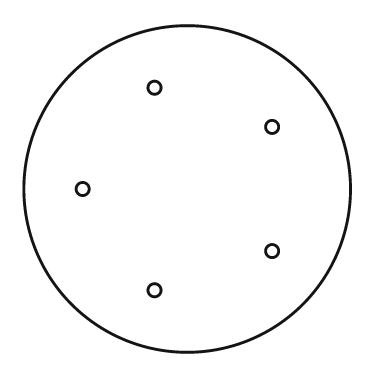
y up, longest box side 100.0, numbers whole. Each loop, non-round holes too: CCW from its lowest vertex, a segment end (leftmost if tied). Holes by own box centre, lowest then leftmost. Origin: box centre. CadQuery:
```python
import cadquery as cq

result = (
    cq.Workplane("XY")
    .moveTo(0.0, 0.0)
    .circle(50.0)
    .moveTo(-10.0, -31.0)
    .circle(2.0)
    .moveTo(26.0, -19.0)
    .circle(2.0)
    .moveTo(-32.0, 0.0)
    .circle(2.0)
    .moveTo(26.0, 19.0)
    .circle(2.0)
    .moveTo(-10.0, 31.0)
    .circle(2.0)
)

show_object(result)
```